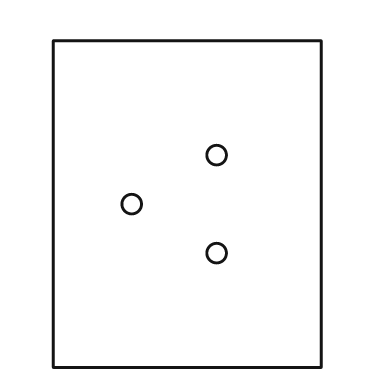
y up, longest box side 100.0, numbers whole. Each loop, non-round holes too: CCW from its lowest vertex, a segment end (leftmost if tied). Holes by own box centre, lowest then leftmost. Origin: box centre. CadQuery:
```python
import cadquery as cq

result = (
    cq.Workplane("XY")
    .moveTo(-41.0, -50.0)
    .lineTo(41.0, -50.0)
    .lineTo(41.0, 50.0)
    .lineTo(-41.0, 50.0)
    .close()
    .moveTo(9.0, -15.0)
    .circle(3.0)
    .moveTo(-17.0, 0.0)
    .circle(3.0)
    .moveTo(9.0, 15.0)
    .circle(3.0)
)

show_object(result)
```